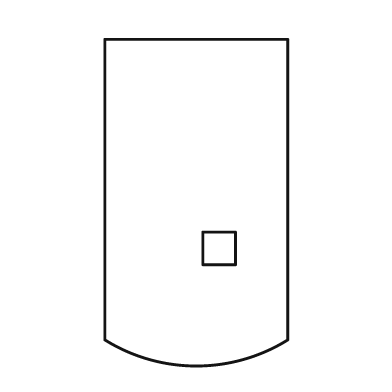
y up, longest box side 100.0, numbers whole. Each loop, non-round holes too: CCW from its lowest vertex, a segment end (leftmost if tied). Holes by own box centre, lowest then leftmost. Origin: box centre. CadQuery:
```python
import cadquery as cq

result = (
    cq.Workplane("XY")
    .moveTo(-28.0, -42.0)
    .threePointArc((0.0, -50.0), (28.0, -42.0))
    .lineTo(28.0, 50.0)
    .lineTo(-28.0, 50.0)
    .close()
    .moveTo(2.0, -19.0)
    .lineTo(12.0, -19.0)
    .lineTo(12.0, -9.0)
    .lineTo(2.0, -9.0)
    .close()
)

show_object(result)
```